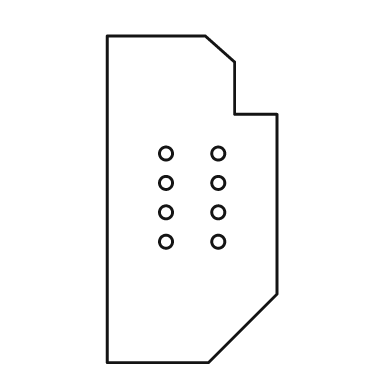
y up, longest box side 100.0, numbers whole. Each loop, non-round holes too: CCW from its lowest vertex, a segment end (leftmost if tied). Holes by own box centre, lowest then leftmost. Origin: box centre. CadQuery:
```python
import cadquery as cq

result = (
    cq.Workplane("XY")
    .moveTo(-26.0, -50.0)
    .lineTo(5.0, -50.0)
    .lineTo(26.0, -29.0)
    .lineTo(26.0, 26.0)
    .lineTo(13.0, 26.0)
    .lineTo(13.0, 42.0)
    .lineTo(4.0, 50.0)
    .lineTo(-26.0, 50.0)
    .close()
    .moveTo(-8.0, -13.0)
    .circle(2.0)
    .moveTo(8.0, -13.0)
    .circle(2.0)
    .moveTo(-8.0, -4.0)
    .circle(2.0)
    .moveTo(8.0, -4.0)
    .circle(2.0)
    .moveTo(-8.0, 5.0)
    .circle(2.0)
    .moveTo(8.0, 5.0)
    .circle(2.0)
    .moveTo(-8.0, 14.0)
    .circle(2.0)
    .moveTo(8.0, 14.0)
    .circle(2.0)
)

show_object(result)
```